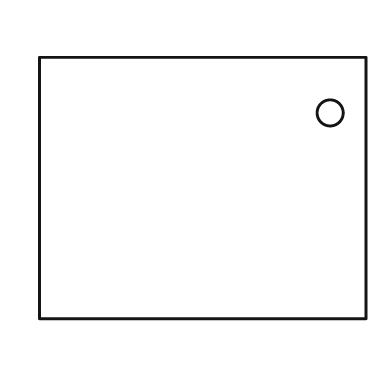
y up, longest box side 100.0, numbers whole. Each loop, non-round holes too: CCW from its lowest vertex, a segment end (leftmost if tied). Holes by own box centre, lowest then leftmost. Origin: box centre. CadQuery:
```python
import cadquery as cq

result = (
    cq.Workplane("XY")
    .moveTo(-50.0, -40.0)
    .lineTo(50.0, -40.0)
    .lineTo(50.0, 40.0)
    .lineTo(-50.0, 40.0)
    .close()
    .moveTo(39.0, 23.0)
    .circle(4.0)
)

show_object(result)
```